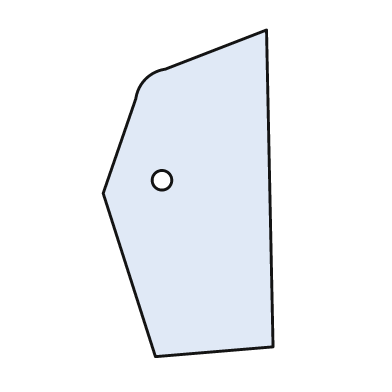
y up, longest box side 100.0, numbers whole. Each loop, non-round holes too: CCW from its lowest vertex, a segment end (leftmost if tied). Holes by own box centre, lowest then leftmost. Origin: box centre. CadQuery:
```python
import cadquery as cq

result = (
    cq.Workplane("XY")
    .moveTo(-10.0, -50.0)
    .lineTo(26.0, -47.0)
    .lineTo(24.0, 50.0)
    .lineTo(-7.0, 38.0)
    .threePointArc((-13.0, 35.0), (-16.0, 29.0))
    .lineTo(-26.0, 0.0)
    .close()
    .moveTo(-8.0, 4.0)
    .circle(3.0)
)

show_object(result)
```